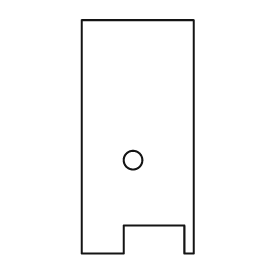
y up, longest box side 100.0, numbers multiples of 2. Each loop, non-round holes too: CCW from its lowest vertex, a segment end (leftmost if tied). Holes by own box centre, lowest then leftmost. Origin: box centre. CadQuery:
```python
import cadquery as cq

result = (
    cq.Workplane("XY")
    .moveTo(-24.0, -50.0)
    .lineTo(-6.0, -50.0)
    .lineTo(-6.0, -38.0)
    .lineTo(20.0, -38.0)
    .lineTo(20.0, -50.0)
    .lineTo(24.0, -50.0)
    .lineTo(24.0, 50.0)
    .lineTo(-24.0, 50.0)
    .close()
    .moveTo(-2.0, -10.0)
    .circle(4.0)
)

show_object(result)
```